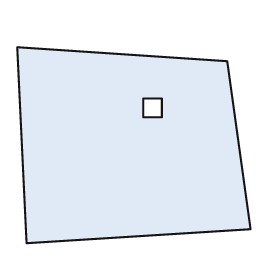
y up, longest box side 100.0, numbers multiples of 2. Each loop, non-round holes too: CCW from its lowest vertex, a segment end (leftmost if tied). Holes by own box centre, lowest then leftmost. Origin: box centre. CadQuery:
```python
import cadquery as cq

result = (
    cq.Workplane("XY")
    .moveTo(-46.0, -42.0)
    .lineTo(50.0, -36.0)
    .lineTo(40.0, 36.0)
    .lineTo(-50.0, 42.0)
    .close()
    .moveTo(4.0, 12.0)
    .lineTo(12.0, 12.0)
    .lineTo(12.0, 20.0)
    .lineTo(4.0, 20.0)
    .close()
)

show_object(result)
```